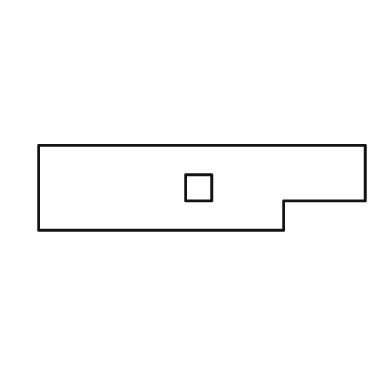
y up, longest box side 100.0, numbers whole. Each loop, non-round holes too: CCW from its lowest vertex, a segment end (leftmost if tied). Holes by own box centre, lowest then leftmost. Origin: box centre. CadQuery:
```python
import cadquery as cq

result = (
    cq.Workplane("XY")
    .moveTo(-50.0, -13.0)
    .lineTo(25.0, -13.0)
    .lineTo(25.0, -4.0)
    .lineTo(50.0, -4.0)
    .lineTo(50.0, 13.0)
    .lineTo(-50.0, 13.0)
    .close()
    .moveTo(-5.0, -4.0)
    .lineTo(3.0, -4.0)
    .lineTo(3.0, 4.0)
    .lineTo(-5.0, 4.0)
    .close()
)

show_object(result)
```